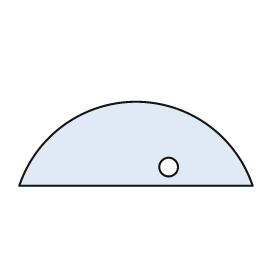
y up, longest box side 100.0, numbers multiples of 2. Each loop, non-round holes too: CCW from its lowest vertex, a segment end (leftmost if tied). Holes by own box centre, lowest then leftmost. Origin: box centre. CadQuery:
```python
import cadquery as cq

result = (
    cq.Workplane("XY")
    .moveTo(-50.0, -18.0)
    .lineTo(50.0, -18.0)
    .threePointArc((0.0, 18.0), (-50.0, -18.0))
    .close()
    .moveTo(14.0, -10.0)
    .circle(4.0)
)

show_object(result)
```